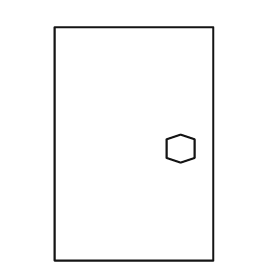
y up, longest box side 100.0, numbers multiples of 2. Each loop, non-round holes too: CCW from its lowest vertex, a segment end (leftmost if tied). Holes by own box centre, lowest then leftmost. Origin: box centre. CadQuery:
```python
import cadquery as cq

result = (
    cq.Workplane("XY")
    .moveTo(-34.0, -50.0)
    .lineTo(34.0, -50.0)
    .lineTo(34.0, 50.0)
    .lineTo(-34.0, 50.0)
    .close()
    .moveTo(20.0, -8.0)
    .lineTo(26.0, -6.0)
    .lineTo(26.0, 2.0)
    .lineTo(20.0, 4.0)
    .lineTo(14.0, 2.0)
    .lineTo(14.0, -6.0)
    .close()
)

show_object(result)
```